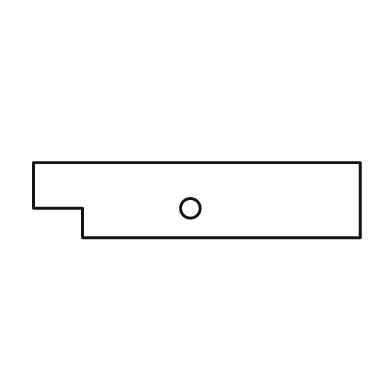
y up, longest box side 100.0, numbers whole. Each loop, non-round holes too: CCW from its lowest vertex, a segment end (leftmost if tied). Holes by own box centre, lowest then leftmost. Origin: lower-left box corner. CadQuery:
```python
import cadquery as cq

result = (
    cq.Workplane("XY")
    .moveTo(15.0, 0.0)
    .lineTo(100.0, 0.0)
    .lineTo(100.0, 23.0)
    .lineTo(0.0, 23.0)
    .lineTo(0.0, 9.0)
    .lineTo(15.0, 9.0)
    .close()
    .moveTo(48.0, 9.0)
    .circle(3.0)
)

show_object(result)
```